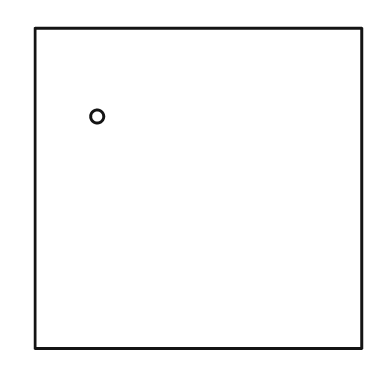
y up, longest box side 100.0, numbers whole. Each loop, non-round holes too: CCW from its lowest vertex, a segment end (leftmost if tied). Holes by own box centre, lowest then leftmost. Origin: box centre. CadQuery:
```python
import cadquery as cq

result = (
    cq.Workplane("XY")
    .moveTo(-50.0, -49.0)
    .lineTo(50.0, -49.0)
    .lineTo(50.0, 49.0)
    .lineTo(-50.0, 49.0)
    .close()
    .moveTo(-31.0, 22.0)
    .circle(2.0)
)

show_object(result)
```